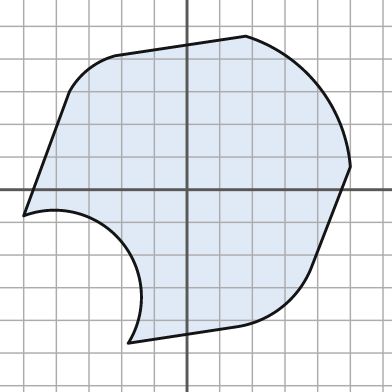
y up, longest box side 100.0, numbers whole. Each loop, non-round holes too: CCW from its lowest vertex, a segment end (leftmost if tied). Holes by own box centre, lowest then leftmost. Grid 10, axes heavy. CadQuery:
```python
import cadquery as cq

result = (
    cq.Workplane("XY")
    .moveTo(-18.0, -47.0)
    .lineTo(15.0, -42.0)
    .threePointArc((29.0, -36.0), (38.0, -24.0))
    .lineTo(50.0, 7.0)
    .threePointArc((40.0, 32.0), (18.0, 47.0))
    .lineTo(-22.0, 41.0)
    .threePointArc((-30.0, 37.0), (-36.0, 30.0))
    .lineTo(-50.0, -8.0)
    .threePointArc((-20.0, -16.0), (-18.0, -47.0))
    .close()
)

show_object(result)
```